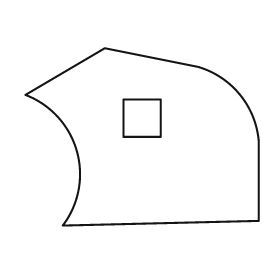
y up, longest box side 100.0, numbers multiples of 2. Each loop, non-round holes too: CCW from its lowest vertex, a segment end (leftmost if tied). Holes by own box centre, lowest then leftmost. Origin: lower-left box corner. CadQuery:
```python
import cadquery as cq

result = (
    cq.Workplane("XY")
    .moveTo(16.0, 0.0)
    .lineTo(100.0, 2.0)
    .lineTo(100.0, 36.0)
    .threePointArc((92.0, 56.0), (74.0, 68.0))
    .lineTo(34.0, 76.0)
    .lineTo(0.0, 56.0)
    .threePointArc((22.0, 32.0), (16.0, 0.0))
    .close()
    .moveTo(42.0, 38.0)
    .lineTo(58.0, 38.0)
    .lineTo(58.0, 54.0)
    .lineTo(42.0, 54.0)
    .close()
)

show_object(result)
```